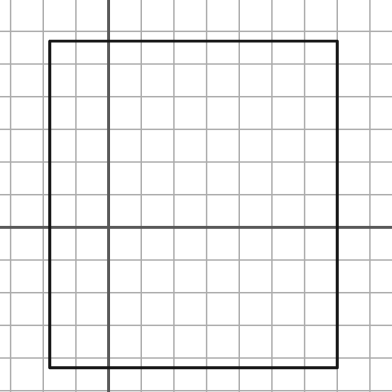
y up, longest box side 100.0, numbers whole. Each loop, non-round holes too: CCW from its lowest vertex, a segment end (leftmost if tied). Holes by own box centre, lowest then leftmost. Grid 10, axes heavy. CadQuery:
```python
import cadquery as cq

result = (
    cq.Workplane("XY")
    .moveTo(-18.0, -43.0)
    .lineTo(70.0, -43.0)
    .lineTo(70.0, 57.0)
    .lineTo(-18.0, 57.0)
    .close()
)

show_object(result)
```